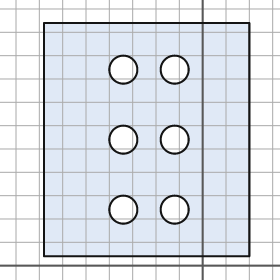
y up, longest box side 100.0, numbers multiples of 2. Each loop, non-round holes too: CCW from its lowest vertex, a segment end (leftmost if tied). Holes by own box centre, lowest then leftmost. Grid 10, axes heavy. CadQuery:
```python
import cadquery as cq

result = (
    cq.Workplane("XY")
    .moveTo(-68.0, 4.0)
    .lineTo(20.0, 4.0)
    .lineTo(20.0, 104.0)
    .lineTo(-68.0, 104.0)
    .close()
    .moveTo(-34.0, 24.0)
    .circle(6.0)
    .moveTo(-12.0, 24.0)
    .circle(6.0)
    .moveTo(-34.0, 54.0)
    .circle(6.0)
    .moveTo(-12.0, 54.0)
    .circle(6.0)
    .moveTo(-34.0, 84.0)
    .circle(6.0)
    .moveTo(-12.0, 84.0)
    .circle(6.0)
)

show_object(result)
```